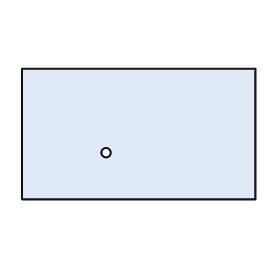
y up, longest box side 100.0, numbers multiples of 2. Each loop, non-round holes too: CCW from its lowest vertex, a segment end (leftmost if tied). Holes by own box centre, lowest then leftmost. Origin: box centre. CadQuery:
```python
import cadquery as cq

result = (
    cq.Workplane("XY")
    .moveTo(-50.0, -28.0)
    .lineTo(50.0, -28.0)
    .lineTo(50.0, 28.0)
    .lineTo(-50.0, 28.0)
    .close()
    .moveTo(-14.0, -8.0)
    .circle(2.0)
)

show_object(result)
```